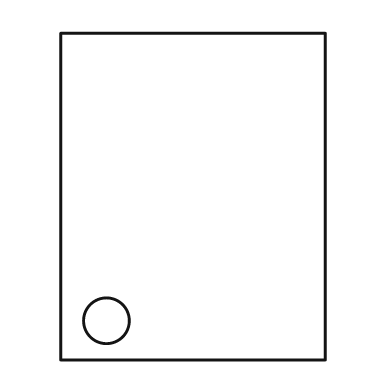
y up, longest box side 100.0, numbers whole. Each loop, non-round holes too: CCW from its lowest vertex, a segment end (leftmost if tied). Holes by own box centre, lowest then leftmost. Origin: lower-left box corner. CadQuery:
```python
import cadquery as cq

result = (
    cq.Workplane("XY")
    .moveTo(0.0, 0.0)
    .lineTo(81.0, 0.0)
    .lineTo(81.0, 100.0)
    .lineTo(0.0, 100.0)
    .close()
    .moveTo(14.0, 12.0)
    .circle(7.0)
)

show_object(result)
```